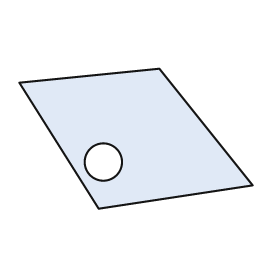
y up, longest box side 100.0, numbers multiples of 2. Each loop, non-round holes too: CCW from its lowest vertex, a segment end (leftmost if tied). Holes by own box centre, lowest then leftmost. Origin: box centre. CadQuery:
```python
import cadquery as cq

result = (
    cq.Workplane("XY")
    .moveTo(-16.0, -30.0)
    .lineTo(50.0, -20.0)
    .lineTo(10.0, 30.0)
    .lineTo(-50.0, 24.0)
    .close()
    .moveTo(-14.0, -10.0)
    .circle(8.0)
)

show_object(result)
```